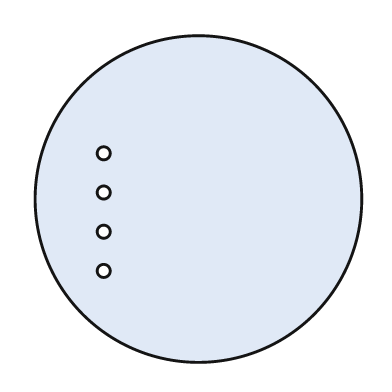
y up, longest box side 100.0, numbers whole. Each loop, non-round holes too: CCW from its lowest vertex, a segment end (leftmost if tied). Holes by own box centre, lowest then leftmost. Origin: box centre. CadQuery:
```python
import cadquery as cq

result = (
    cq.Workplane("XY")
    .moveTo(0.0, 0.0)
    .circle(50.0)
    .moveTo(-29.0, -22.0)
    .circle(2.0)
    .moveTo(-29.0, -10.0)
    .circle(2.0)
    .moveTo(-29.0, 2.0)
    .circle(2.0)
    .moveTo(-29.0, 14.0)
    .circle(2.0)
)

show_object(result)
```